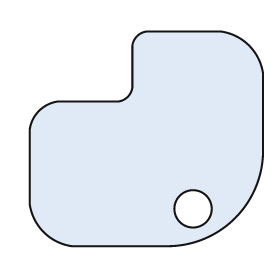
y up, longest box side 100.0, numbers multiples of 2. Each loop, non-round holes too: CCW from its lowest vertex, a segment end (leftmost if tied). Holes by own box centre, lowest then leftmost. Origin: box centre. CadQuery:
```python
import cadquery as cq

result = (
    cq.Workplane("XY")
    .moveTo(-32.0, -46.0)
    .lineTo(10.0, -46.0)
    .threePointArc((38.0, -34.0), (50.0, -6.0))
    .lineTo(50.0, 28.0)
    .threePointArc((44.0, 40.0), (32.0, 46.0))
    .lineTo(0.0, 46.0)
    .threePointArc((-4.0, 44.0), (-6.0, 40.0))
    .lineTo(-6.0, 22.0)
    .threePointArc((-8.0, 18.0), (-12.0, 16.0))
    .lineTo(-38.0, 16.0)
    .threePointArc((-46.0, 12.0), (-50.0, 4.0))
    .lineTo(-50.0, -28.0)
    .threePointArc((-44.0, -40.0), (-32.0, -46.0))
    .close()
    .moveTo(20.0, -30.0)
    .circle(8.0)
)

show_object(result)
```